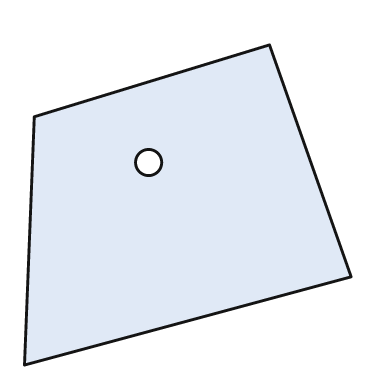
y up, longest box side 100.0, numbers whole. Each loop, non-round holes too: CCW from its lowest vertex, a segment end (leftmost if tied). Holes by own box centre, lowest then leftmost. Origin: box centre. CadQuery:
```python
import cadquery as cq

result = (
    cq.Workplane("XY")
    .moveTo(-50.0, -49.0)
    .lineTo(50.0, -22.0)
    .lineTo(25.0, 49.0)
    .lineTo(-47.0, 27.0)
    .close()
    .moveTo(-12.0, 13.0)
    .circle(4.0)
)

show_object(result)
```